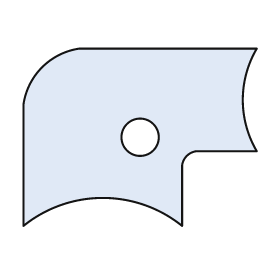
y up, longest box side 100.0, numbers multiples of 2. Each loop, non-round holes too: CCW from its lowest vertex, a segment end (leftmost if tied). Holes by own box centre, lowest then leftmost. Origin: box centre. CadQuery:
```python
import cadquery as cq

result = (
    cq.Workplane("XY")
    .moveTo(-50.0, -38.0)
    .threePointArc((-16.0, -26.0), (18.0, -38.0))
    .lineTo(18.0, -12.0)
    .threePointArc((20.0, -8.0), (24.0, -6.0))
    .lineTo(50.0, -6.0)
    .threePointArc((44.0, 16.0), (50.0, 38.0))
    .lineTo(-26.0, 38.0)
    .threePointArc((-42.0, 30.0), (-50.0, 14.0))
    .close()
    .moveTo(0.0, 0.0)
    .circle(8.0)
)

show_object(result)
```